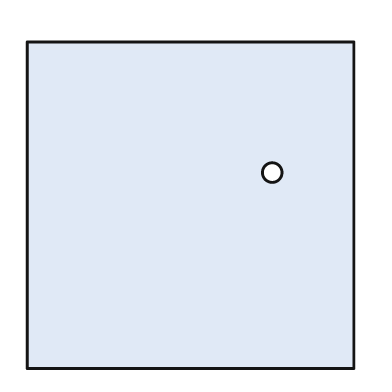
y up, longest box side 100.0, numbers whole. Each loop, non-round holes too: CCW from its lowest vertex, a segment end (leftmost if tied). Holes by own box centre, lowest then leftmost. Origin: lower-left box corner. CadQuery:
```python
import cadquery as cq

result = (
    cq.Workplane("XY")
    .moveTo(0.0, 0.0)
    .lineTo(100.0, 0.0)
    .lineTo(100.0, 100.0)
    .lineTo(0.0, 100.0)
    .close()
    .moveTo(75.0, 60.0)
    .circle(3.0)
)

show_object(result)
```